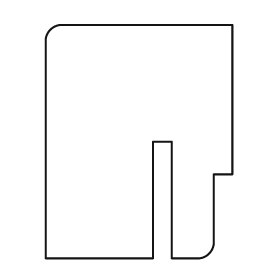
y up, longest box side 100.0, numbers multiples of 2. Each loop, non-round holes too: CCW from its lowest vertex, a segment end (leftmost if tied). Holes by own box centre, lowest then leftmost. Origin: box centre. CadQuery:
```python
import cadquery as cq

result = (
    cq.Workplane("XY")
    .moveTo(-40.0, -50.0)
    .lineTo(6.0, -50.0)
    .lineTo(6.0, 0.0)
    .lineTo(14.0, 0.0)
    .lineTo(14.0, -50.0)
    .lineTo(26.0, -50.0)
    .threePointArc((30.0, -48.0), (32.0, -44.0))
    .lineTo(32.0, -14.0)
    .lineTo(40.0, -14.0)
    .lineTo(40.0, 50.0)
    .lineTo(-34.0, 50.0)
    .threePointArc((-38.0, 48.0), (-40.0, 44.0))
    .close()
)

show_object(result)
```